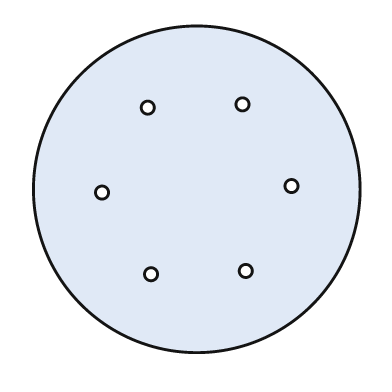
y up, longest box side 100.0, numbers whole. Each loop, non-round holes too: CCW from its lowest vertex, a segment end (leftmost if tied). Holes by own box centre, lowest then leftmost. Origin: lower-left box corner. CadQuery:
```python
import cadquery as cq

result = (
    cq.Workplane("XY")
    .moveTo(50.0, 50.0)
    .circle(50.0)
    .moveTo(36.0, 24.0)
    .circle(2.0)
    .moveTo(65.0, 25.0)
    .circle(2.0)
    .moveTo(21.0, 49.0)
    .circle(2.0)
    .moveTo(79.0, 51.0)
    .circle(2.0)
    .moveTo(35.0, 75.0)
    .circle(2.0)
    .moveTo(64.0, 76.0)
    .circle(2.0)
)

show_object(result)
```